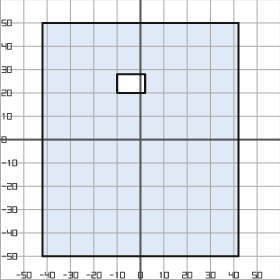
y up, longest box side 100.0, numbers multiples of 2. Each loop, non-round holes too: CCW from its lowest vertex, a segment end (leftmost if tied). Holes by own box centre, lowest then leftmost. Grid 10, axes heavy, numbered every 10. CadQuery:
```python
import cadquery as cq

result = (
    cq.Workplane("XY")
    .moveTo(-42.0, -50.0)
    .lineTo(42.0, -50.0)
    .lineTo(42.0, 50.0)
    .lineTo(-42.0, 50.0)
    .close()
    .moveTo(-10.0, 20.0)
    .lineTo(2.0, 20.0)
    .lineTo(2.0, 28.0)
    .lineTo(-10.0, 28.0)
    .close()
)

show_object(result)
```